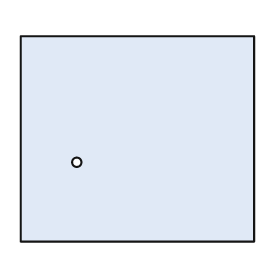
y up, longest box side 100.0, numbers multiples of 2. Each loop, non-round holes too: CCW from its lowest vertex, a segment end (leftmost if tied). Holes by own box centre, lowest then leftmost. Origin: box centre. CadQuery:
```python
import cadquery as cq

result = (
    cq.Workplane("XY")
    .moveTo(-50.0, -44.0)
    .lineTo(50.0, -44.0)
    .lineTo(50.0, 44.0)
    .lineTo(-50.0, 44.0)
    .close()
    .moveTo(-26.0, -10.0)
    .circle(2.0)
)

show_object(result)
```